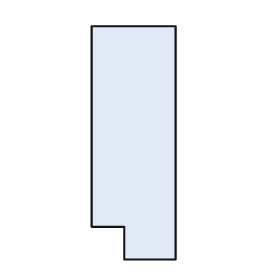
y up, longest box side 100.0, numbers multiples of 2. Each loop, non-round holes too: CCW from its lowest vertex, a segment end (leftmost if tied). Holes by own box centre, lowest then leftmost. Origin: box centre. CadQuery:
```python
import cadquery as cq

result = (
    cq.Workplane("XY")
    .moveTo(-4.0, -50.0)
    .lineTo(18.0, -50.0)
    .lineTo(18.0, 50.0)
    .lineTo(-18.0, 50.0)
    .lineTo(-18.0, -36.0)
    .lineTo(-4.0, -36.0)
    .close()
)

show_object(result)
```